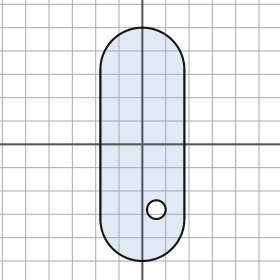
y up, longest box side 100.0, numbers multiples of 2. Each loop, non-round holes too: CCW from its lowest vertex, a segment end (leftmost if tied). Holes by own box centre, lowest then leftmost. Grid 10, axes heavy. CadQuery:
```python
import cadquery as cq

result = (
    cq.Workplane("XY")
    .moveTo(-18.0, -32.0)
    .threePointArc((0.0, -50.0), (18.0, -32.0))
    .lineTo(18.0, 32.0)
    .threePointArc((0.0, 50.0), (-18.0, 32.0))
    .close()
    .moveTo(6.0, -28.0)
    .circle(4.0)
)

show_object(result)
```